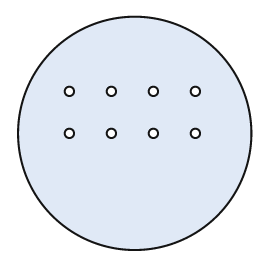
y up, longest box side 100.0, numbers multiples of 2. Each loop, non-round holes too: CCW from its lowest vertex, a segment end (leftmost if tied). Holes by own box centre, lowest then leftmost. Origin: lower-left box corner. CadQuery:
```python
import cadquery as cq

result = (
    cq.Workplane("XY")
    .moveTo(50.0, 50.0)
    .circle(50.0)
    .moveTo(22.0, 50.0)
    .circle(2.0)
    .moveTo(40.0, 50.0)
    .circle(2.0)
    .moveTo(58.0, 50.0)
    .circle(2.0)
    .moveTo(76.0, 50.0)
    .circle(2.0)
    .moveTo(22.0, 68.0)
    .circle(2.0)
    .moveTo(40.0, 68.0)
    .circle(2.0)
    .moveTo(58.0, 68.0)
    .circle(2.0)
    .moveTo(76.0, 68.0)
    .circle(2.0)
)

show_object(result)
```